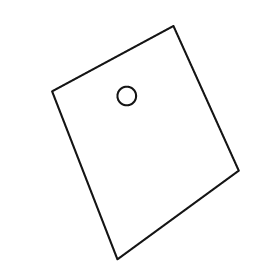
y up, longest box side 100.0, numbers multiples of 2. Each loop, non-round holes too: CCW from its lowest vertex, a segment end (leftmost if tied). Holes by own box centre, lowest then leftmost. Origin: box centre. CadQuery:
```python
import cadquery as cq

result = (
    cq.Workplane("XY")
    .moveTo(-12.0, -50.0)
    .lineTo(40.0, -12.0)
    .lineTo(12.0, 50.0)
    .lineTo(-40.0, 22.0)
    .close()
    .moveTo(-8.0, 20.0)
    .circle(4.0)
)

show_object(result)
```